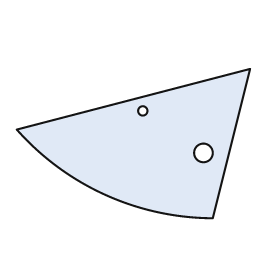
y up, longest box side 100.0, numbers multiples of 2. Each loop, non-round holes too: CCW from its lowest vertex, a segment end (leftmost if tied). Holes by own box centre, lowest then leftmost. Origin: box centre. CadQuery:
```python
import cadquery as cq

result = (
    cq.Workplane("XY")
    .moveTo(34.0, -32.0)
    .lineTo(50.0, 32.0)
    .lineTo(-50.0, 6.0)
    .threePointArc((-12.0, -22.0), (34.0, -32.0))
    .close()
    .moveTo(30.0, -4.0)
    .circle(4.0)
    .moveTo(4.0, 14.0)
    .circle(2.0)
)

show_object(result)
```